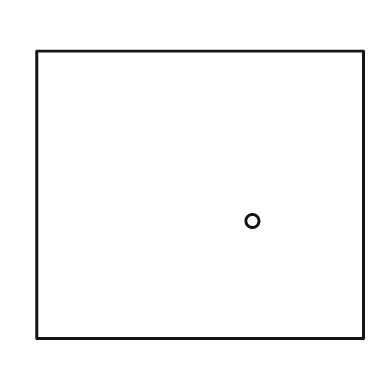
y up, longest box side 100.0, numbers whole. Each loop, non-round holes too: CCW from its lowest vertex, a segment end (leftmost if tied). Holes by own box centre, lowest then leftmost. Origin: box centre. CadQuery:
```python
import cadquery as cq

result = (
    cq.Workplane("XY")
    .moveTo(-50.0, -44.0)
    .lineTo(50.0, -44.0)
    .lineTo(50.0, 44.0)
    .lineTo(-50.0, 44.0)
    .close()
    .moveTo(16.0, -8.0)
    .circle(2.0)
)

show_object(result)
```